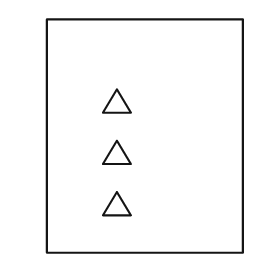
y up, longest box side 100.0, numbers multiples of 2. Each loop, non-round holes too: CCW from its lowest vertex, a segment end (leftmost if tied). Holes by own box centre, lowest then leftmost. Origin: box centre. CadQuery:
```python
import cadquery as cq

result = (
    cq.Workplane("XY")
    .moveTo(-42.0, -50.0)
    .lineTo(42.0, -50.0)
    .lineTo(42.0, 50.0)
    .lineTo(-42.0, 50.0)
    .close()
    .moveTo(-18.0, -34.0)
    .lineTo(-6.0, -34.0)
    .lineTo(-12.0, -24.0)
    .close()
    .moveTo(-18.0, -12.0)
    .lineTo(-6.0, -12.0)
    .lineTo(-12.0, -2.0)
    .close()
    .moveTo(-18.0, 10.0)
    .lineTo(-6.0, 10.0)
    .lineTo(-12.0, 20.0)
    .close()
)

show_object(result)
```